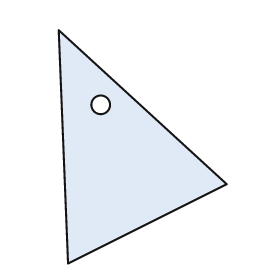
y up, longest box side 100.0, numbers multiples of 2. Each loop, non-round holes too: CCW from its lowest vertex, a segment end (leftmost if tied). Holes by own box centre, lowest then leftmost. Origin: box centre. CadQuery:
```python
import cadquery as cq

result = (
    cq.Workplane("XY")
    .moveTo(-32.0, -50.0)
    .lineTo(36.0, -16.0)
    .lineTo(-36.0, 50.0)
    .close()
    .moveTo(-18.0, 18.0)
    .circle(4.0)
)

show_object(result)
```